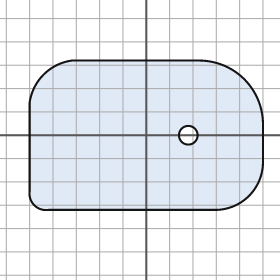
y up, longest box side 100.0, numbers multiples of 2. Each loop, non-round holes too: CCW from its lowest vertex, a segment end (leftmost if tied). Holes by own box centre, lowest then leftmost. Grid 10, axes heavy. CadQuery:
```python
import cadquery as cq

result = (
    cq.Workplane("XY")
    .moveTo(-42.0, -32.0)
    .lineTo(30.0, -32.0)
    .threePointArc((44.0, -26.0), (50.0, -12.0))
    .lineTo(50.0, 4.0)
    .threePointArc((42.0, 24.0), (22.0, 32.0))
    .lineTo(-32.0, 32.0)
    .threePointArc((-44.0, 26.0), (-50.0, 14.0))
    .lineTo(-50.0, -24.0)
    .threePointArc((-48.0, -30.0), (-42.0, -32.0))
    .close()
    .moveTo(18.0, 0.0)
    .circle(4.0)
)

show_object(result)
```